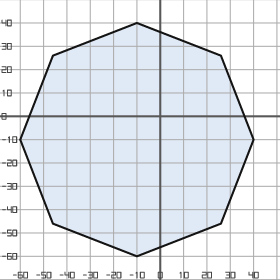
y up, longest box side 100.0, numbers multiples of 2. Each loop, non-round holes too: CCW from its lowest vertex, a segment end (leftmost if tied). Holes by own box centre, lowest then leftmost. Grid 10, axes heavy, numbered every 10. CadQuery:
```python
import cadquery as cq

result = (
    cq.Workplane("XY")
    .moveTo(-10.0, -60.0)
    .lineTo(26.0, -46.0)
    .lineTo(40.0, -10.0)
    .lineTo(26.0, 26.0)
    .lineTo(-10.0, 40.0)
    .lineTo(-46.0, 26.0)
    .lineTo(-60.0, -10.0)
    .lineTo(-46.0, -46.0)
    .close()
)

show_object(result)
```